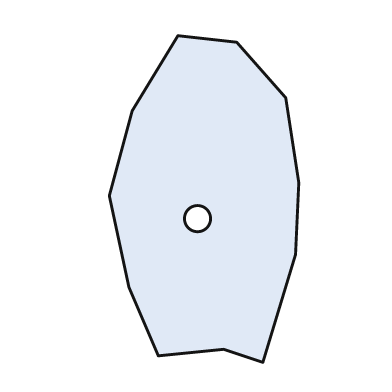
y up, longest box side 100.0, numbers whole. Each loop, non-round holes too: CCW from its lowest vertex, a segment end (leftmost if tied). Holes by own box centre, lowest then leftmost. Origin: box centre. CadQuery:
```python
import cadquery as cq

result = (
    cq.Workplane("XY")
    .moveTo(18.0, -50.0)
    .lineTo(28.0, -17.0)
    .lineTo(29.0, 5.0)
    .lineTo(25.0, 31.0)
    .lineTo(10.0, 48.0)
    .lineTo(-8.0, 50.0)
    .lineTo(-22.0, 27.0)
    .lineTo(-29.0, 1.0)
    .lineTo(-23.0, -27.0)
    .lineTo(-14.0, -48.0)
    .lineTo(6.0, -46.0)
    .close()
    .moveTo(-2.0, -6.0)
    .circle(4.0)
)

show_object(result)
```